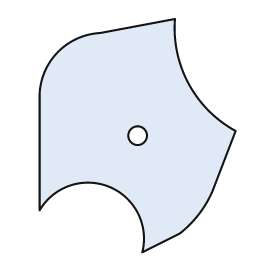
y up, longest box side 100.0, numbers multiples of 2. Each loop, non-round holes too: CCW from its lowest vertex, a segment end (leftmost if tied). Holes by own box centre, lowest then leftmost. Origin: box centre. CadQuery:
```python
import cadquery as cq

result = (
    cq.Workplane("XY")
    .moveTo(2.0, -50.0)
    .lineTo(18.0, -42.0)
    .threePointArc((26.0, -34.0), (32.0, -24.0))
    .lineTo(42.0, 2.0)
    .threePointArc((22.0, 22.0), (16.0, 50.0))
    .lineTo(-16.0, 44.0)
    .threePointArc((-34.0, 36.0), (-42.0, 18.0))
    .lineTo(-42.0, -32.0)
    .threePointArc((-12.0, -22.0), (2.0, -50.0))
    .close()
    .moveTo(0.0, 0.0)
    .circle(4.0)
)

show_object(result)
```